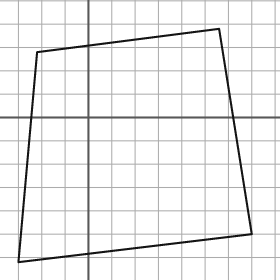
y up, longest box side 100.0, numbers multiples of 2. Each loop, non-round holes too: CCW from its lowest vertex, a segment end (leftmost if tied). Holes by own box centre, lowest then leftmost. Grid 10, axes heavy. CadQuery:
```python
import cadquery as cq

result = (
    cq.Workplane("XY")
    .moveTo(-30.0, -62.0)
    .lineTo(70.0, -50.0)
    .lineTo(56.0, 38.0)
    .lineTo(-22.0, 28.0)
    .close()
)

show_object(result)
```